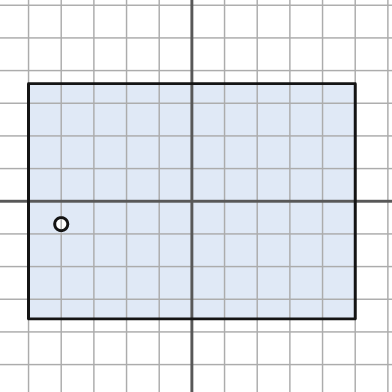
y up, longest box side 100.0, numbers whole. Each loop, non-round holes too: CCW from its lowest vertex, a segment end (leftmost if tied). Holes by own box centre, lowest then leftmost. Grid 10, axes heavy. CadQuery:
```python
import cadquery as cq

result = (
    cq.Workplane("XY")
    .moveTo(-50.0, -36.0)
    .lineTo(50.0, -36.0)
    .lineTo(50.0, 36.0)
    .lineTo(-50.0, 36.0)
    .close()
    .moveTo(-40.0, -7.0)
    .circle(2.0)
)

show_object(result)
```